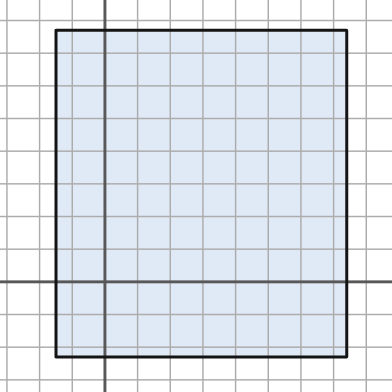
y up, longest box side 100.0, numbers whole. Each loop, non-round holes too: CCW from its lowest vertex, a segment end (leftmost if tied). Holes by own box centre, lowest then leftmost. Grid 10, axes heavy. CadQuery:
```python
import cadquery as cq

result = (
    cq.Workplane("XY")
    .moveTo(-15.0, -23.0)
    .lineTo(74.0, -23.0)
    .lineTo(74.0, 77.0)
    .lineTo(-15.0, 77.0)
    .close()
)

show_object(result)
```